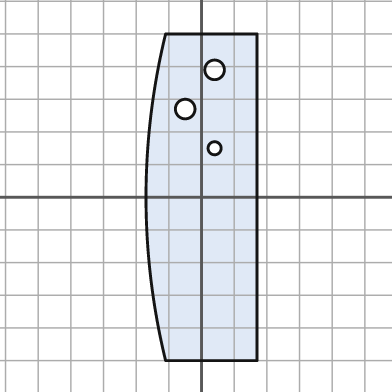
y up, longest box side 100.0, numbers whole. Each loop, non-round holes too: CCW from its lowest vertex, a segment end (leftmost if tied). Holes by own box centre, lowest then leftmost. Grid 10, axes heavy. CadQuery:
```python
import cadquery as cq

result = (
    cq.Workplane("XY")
    .moveTo(-11.0, -50.0)
    .lineTo(17.0, -50.0)
    .lineTo(17.0, 50.0)
    .lineTo(-11.0, 50.0)
    .threePointArc((-17.0, 0.0), (-11.0, -50.0))
    .close()
    .moveTo(4.0, 15.0)
    .circle(2.0)
    .moveTo(-5.0, 27.0)
    .circle(3.0)
    .moveTo(4.0, 39.0)
    .circle(3.0)
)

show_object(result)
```